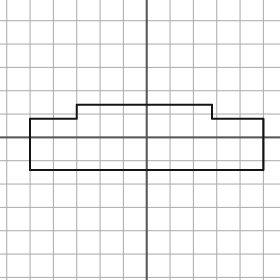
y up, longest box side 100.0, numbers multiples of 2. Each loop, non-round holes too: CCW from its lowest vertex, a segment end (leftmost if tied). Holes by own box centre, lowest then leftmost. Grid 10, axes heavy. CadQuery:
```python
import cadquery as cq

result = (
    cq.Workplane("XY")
    .moveTo(-50.0, -14.0)
    .lineTo(50.0, -14.0)
    .lineTo(50.0, 8.0)
    .lineTo(28.0, 8.0)
    .lineTo(28.0, 14.0)
    .lineTo(-30.0, 14.0)
    .lineTo(-30.0, 8.0)
    .lineTo(-50.0, 8.0)
    .close()
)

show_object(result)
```